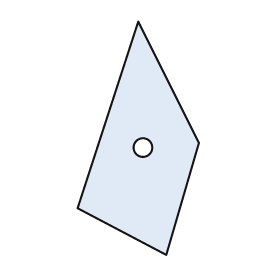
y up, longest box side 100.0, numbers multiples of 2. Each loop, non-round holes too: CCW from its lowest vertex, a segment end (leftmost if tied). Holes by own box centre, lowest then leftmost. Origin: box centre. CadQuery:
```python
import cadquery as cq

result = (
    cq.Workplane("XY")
    .moveTo(12.0, -50.0)
    .lineTo(26.0, -2.0)
    .lineTo(0.0, 50.0)
    .lineTo(-26.0, -30.0)
    .close()
    .moveTo(2.0, -4.0)
    .circle(4.0)
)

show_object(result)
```